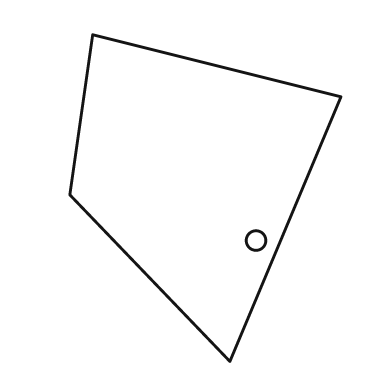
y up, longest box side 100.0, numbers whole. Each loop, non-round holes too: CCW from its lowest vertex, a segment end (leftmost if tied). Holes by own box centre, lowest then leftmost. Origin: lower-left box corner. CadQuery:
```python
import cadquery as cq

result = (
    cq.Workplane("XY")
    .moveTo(49.0, 0.0)
    .lineTo(83.0, 81.0)
    .lineTo(7.0, 100.0)
    .lineTo(0.0, 51.0)
    .close()
    .moveTo(57.0, 37.0)
    .circle(3.0)
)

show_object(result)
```